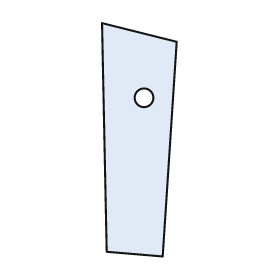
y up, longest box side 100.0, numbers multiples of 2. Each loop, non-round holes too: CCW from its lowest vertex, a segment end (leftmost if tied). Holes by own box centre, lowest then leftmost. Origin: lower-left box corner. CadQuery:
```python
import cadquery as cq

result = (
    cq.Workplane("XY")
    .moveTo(26.0, 0.0)
    .lineTo(32.0, 92.0)
    .lineTo(0.0, 100.0)
    .lineTo(2.0, 2.0)
    .close()
    .moveTo(18.0, 68.0)
    .circle(4.0)
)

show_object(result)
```